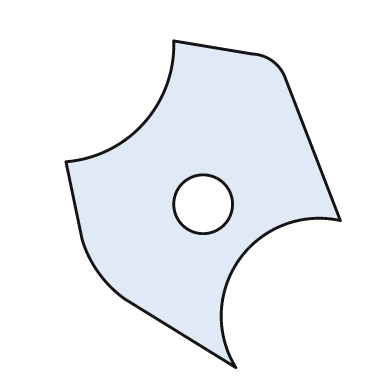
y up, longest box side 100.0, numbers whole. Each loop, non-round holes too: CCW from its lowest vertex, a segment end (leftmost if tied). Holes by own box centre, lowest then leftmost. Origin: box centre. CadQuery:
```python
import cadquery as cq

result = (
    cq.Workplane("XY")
    .moveTo(10.0, -50.0)
    .threePointArc((11.0, -17.0), (42.0, -5.0))
    .lineTo(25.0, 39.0)
    .threePointArc((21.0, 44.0), (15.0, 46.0))
    .lineTo(-9.0, 50.0)
    .threePointArc((-18.0, 25.0), (-42.0, 13.0))
    .lineTo(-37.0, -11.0)
    .threePointArc((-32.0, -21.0), (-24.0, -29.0))
    .close()
    .moveTo(0.0, 0.0)
    .circle(9.0)
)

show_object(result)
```